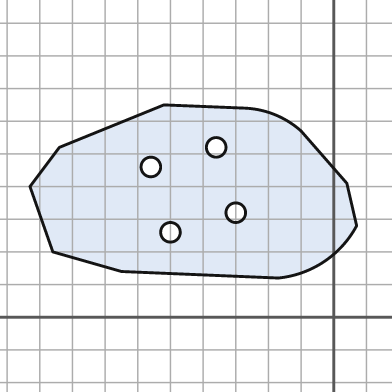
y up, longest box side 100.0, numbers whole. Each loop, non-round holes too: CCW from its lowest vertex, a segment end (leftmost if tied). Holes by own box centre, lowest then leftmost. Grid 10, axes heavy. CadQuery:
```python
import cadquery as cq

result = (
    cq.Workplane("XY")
    .moveTo(-17.0, 12.0)
    .threePointArc((-3.0, 17.0), (7.0, 28.0))
    .lineTo(4.0, 41.0)
    .lineTo(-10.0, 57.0)
    .threePointArc((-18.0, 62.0), (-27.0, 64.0))
    .lineTo(-52.0, 65.0)
    .lineTo(-84.0, 52.0)
    .lineTo(-93.0, 40.0)
    .lineTo(-86.0, 20.0)
    .lineTo(-65.0, 14.0)
    .close()
    .moveTo(-50.0, 26.0)
    .circle(3.0)
    .moveTo(-30.0, 32.0)
    .circle(3.0)
    .moveTo(-56.0, 46.0)
    .circle(3.0)
    .moveTo(-36.0, 52.0)
    .circle(3.0)
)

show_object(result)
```